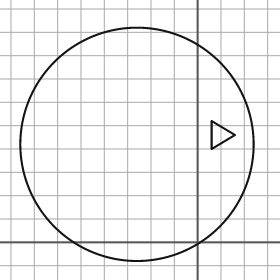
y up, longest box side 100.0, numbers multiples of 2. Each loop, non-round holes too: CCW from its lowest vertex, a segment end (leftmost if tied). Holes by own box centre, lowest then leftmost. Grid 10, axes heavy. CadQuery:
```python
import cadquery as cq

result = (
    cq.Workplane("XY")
    .moveTo(-26.0, 42.0)
    .circle(50.0)
    .moveTo(6.0, 40.0)
    .lineTo(16.0, 46.0)
    .lineTo(6.0, 52.0)
    .close()
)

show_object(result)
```